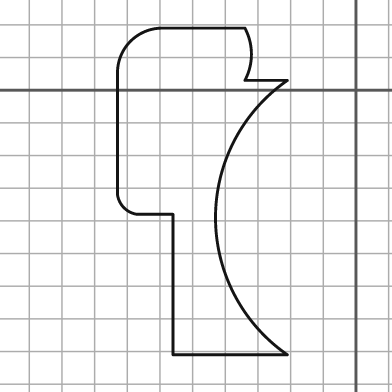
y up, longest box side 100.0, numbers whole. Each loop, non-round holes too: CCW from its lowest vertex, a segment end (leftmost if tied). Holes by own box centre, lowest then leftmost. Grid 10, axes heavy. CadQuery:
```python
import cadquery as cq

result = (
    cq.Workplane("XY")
    .moveTo(-56.0, -81.0)
    .lineTo(-21.0, -81.0)
    .threePointArc((-43.0, -39.0), (-21.0, 3.0))
    .lineTo(-34.0, 3.0)
    .threePointArc((-32.0, 11.0), (-34.0, 19.0))
    .lineTo(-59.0, 19.0)
    .threePointArc((-69.0, 15.0), (-73.0, 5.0))
    .lineTo(-73.0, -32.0)
    .threePointArc((-71.0, -36.0), (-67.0, -38.0))
    .lineTo(-56.0, -38.0)
    .close()
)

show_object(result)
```